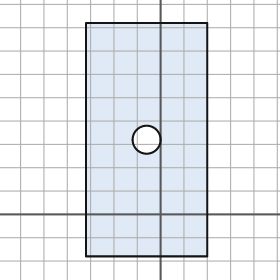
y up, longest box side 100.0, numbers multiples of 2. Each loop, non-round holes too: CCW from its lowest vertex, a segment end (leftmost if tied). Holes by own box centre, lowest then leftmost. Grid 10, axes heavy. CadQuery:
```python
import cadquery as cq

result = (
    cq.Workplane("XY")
    .moveTo(-32.0, -18.0)
    .lineTo(20.0, -18.0)
    .lineTo(20.0, 82.0)
    .lineTo(-32.0, 82.0)
    .close()
    .moveTo(-6.0, 32.0)
    .circle(6.0)
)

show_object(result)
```